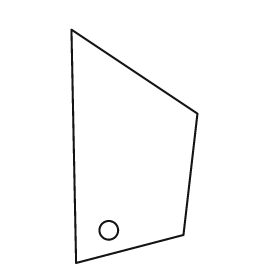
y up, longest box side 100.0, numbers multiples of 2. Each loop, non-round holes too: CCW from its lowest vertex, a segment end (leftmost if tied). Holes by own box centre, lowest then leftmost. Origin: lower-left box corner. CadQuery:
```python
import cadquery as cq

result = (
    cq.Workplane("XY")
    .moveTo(2.0, 0.0)
    .lineTo(48.0, 12.0)
    .lineTo(54.0, 64.0)
    .lineTo(0.0, 100.0)
    .close()
    .moveTo(16.0, 14.0)
    .circle(4.0)
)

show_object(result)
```